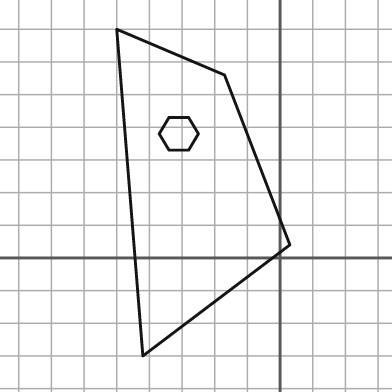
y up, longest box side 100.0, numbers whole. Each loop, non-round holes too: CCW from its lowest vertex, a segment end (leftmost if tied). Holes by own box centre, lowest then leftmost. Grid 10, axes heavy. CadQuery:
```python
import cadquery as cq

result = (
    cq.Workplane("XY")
    .moveTo(-42.0, -30.0)
    .lineTo(3.0, 4.0)
    .lineTo(-17.0, 56.0)
    .lineTo(-50.0, 70.0)
    .close()
    .moveTo(-34.0, 33.0)
    .lineTo(-28.0, 33.0)
    .lineTo(-25.0, 38.0)
    .lineTo(-28.0, 43.0)
    .lineTo(-34.0, 43.0)
    .lineTo(-37.0, 38.0)
    .close()
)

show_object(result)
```